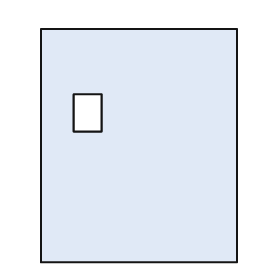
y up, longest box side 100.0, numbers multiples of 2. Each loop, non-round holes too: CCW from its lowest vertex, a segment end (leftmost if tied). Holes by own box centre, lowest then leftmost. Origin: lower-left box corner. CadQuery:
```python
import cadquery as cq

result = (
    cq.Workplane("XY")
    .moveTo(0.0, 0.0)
    .lineTo(84.0, 0.0)
    .lineTo(84.0, 100.0)
    .lineTo(0.0, 100.0)
    .close()
    .moveTo(14.0, 56.0)
    .lineTo(26.0, 56.0)
    .lineTo(26.0, 72.0)
    .lineTo(14.0, 72.0)
    .close()
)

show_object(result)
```